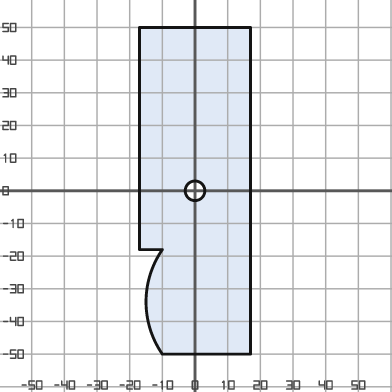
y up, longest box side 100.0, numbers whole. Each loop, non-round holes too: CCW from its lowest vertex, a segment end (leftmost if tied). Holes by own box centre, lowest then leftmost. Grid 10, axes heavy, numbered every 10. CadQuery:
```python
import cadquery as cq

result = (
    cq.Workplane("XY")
    .moveTo(-10.0, -50.0)
    .lineTo(17.0, -50.0)
    .lineTo(17.0, 50.0)
    .lineTo(-17.0, 50.0)
    .lineTo(-17.0, -18.0)
    .lineTo(-10.0, -18.0)
    .threePointArc((-15.0, -34.0), (-10.0, -50.0))
    .close()
    .moveTo(0.0, 0.0)
    .circle(3.0)
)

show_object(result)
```